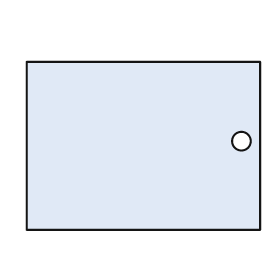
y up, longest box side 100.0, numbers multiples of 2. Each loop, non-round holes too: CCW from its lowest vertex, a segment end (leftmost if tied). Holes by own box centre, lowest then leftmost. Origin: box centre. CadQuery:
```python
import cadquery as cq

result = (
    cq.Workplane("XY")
    .moveTo(-50.0, -36.0)
    .lineTo(50.0, -36.0)
    .lineTo(50.0, 36.0)
    .lineTo(-50.0, 36.0)
    .close()
    .moveTo(42.0, 2.0)
    .circle(4.0)
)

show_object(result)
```